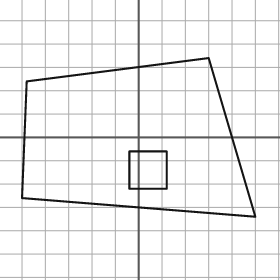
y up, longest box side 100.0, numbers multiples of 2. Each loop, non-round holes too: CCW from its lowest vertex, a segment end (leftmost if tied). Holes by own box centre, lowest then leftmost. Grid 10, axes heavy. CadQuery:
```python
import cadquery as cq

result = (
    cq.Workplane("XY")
    .moveTo(50.0, -34.0)
    .lineTo(30.0, 34.0)
    .lineTo(-48.0, 24.0)
    .lineTo(-50.0, -26.0)
    .close()
    .moveTo(-4.0, -22.0)
    .lineTo(12.0, -22.0)
    .lineTo(12.0, -6.0)
    .lineTo(-4.0, -6.0)
    .close()
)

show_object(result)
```